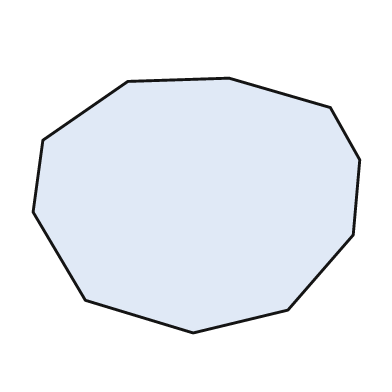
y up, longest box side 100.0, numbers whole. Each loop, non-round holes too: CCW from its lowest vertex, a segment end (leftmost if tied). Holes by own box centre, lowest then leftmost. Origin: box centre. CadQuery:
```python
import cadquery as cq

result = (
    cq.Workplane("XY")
    .moveTo(-1.0, -39.0)
    .lineTo(28.0, -32.0)
    .lineTo(48.0, -9.0)
    .lineTo(50.0, 14.0)
    .lineTo(41.0, 30.0)
    .lineTo(10.0, 39.0)
    .lineTo(-21.0, 38.0)
    .lineTo(-47.0, 20.0)
    .lineTo(-50.0, -2.0)
    .lineTo(-34.0, -29.0)
    .close()
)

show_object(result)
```